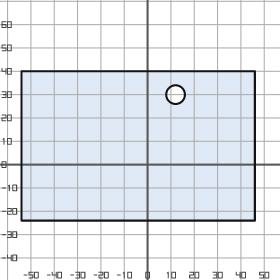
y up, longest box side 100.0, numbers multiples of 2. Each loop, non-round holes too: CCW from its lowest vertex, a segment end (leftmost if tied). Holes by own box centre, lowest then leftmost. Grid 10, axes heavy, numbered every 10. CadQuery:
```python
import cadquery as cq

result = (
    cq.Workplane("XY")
    .moveTo(-54.0, -24.0)
    .lineTo(46.0, -24.0)
    .lineTo(46.0, 40.0)
    .lineTo(-54.0, 40.0)
    .close()
    .moveTo(12.0, 30.0)
    .circle(4.0)
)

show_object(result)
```